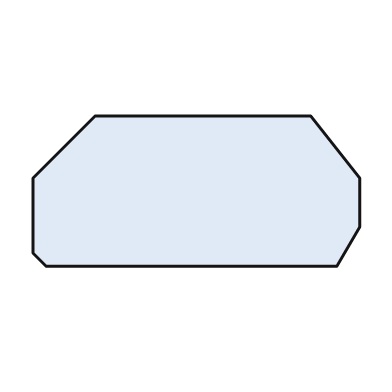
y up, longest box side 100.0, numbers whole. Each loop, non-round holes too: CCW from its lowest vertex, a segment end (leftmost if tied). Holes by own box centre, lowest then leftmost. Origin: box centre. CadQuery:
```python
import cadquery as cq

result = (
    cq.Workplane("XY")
    .moveTo(-46.0, -23.0)
    .lineTo(43.0, -23.0)
    .lineTo(50.0, -11.0)
    .lineTo(50.0, 4.0)
    .lineTo(35.0, 23.0)
    .lineTo(-31.0, 23.0)
    .lineTo(-50.0, 4.0)
    .lineTo(-50.0, -19.0)
    .close()
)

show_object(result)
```